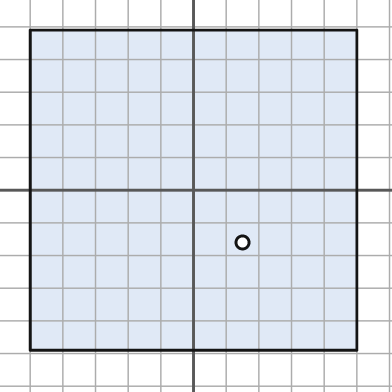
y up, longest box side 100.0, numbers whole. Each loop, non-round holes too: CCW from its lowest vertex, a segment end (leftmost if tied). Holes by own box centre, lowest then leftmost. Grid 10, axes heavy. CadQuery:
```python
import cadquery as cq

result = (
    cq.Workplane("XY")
    .moveTo(-50.0, -49.0)
    .lineTo(50.0, -49.0)
    .lineTo(50.0, 49.0)
    .lineTo(-50.0, 49.0)
    .close()
    .moveTo(15.0, -16.0)
    .circle(2.0)
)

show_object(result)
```